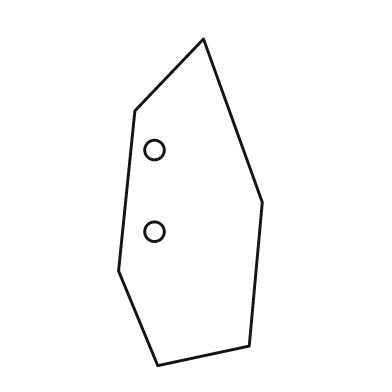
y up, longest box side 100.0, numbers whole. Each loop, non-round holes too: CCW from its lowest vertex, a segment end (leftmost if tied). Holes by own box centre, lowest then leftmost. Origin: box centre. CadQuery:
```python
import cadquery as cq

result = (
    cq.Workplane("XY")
    .moveTo(-10.0, -50.0)
    .lineTo(18.0, -44.0)
    .lineTo(22.0, 0.0)
    .lineTo(4.0, 50.0)
    .lineTo(-17.0, 28.0)
    .lineTo(-22.0, -21.0)
    .close()
    .moveTo(-11.0, -9.0)
    .circle(3.0)
    .moveTo(-11.0, 16.0)
    .circle(3.0)
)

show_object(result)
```